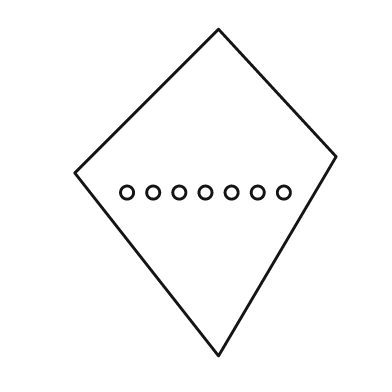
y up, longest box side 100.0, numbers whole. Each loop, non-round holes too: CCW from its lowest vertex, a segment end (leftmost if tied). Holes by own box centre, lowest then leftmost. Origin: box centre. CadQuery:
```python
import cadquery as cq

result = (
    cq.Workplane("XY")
    .moveTo(4.0, -50.0)
    .lineTo(40.0, 11.0)
    .lineTo(4.0, 50.0)
    .lineTo(-40.0, 6.0)
    .close()
    .moveTo(-24.0, 0.0)
    .circle(2.0)
    .moveTo(-16.0, 0.0)
    .circle(2.0)
    .moveTo(-8.0, 0.0)
    .circle(2.0)
    .moveTo(0.0, 0.0)
    .circle(2.0)
    .moveTo(8.0, 0.0)
    .circle(2.0)
    .moveTo(16.0, 0.0)
    .circle(2.0)
    .moveTo(24.0, 0.0)
    .circle(2.0)
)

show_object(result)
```